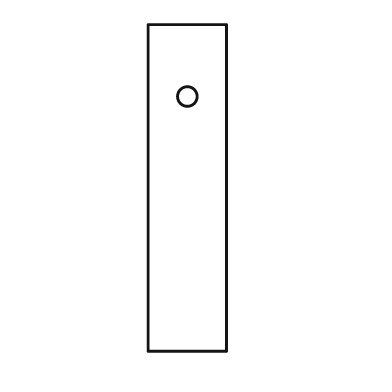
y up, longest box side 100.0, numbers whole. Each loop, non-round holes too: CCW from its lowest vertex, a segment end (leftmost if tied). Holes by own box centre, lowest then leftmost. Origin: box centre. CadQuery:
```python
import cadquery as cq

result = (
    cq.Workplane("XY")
    .moveTo(-12.0, -50.0)
    .lineTo(12.0, -50.0)
    .lineTo(12.0, 50.0)
    .lineTo(-12.0, 50.0)
    .close()
    .moveTo(0.0, 28.0)
    .circle(3.0)
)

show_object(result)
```